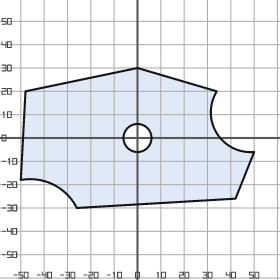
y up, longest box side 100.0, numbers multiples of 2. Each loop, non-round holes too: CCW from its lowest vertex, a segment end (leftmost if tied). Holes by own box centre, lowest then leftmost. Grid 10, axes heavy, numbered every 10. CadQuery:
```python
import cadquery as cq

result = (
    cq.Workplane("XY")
    .moveTo(-26.0, -30.0)
    .lineTo(42.0, -26.0)
    .lineTo(50.0, -6.0)
    .threePointArc((34.0, 2.0), (34.0, 20.0))
    .lineTo(0.0, 30.0)
    .lineTo(-48.0, 20.0)
    .lineTo(-50.0, -18.0)
    .threePointArc((-36.0, -20.0), (-26.0, -30.0))
    .close()
    .moveTo(0.0, 0.0)
    .circle(6.0)
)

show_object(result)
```